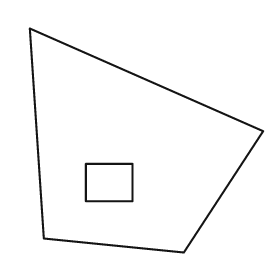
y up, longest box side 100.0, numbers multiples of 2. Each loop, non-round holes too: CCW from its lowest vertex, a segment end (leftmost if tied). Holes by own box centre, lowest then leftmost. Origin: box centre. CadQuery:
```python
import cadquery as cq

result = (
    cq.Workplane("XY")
    .moveTo(16.0, -48.0)
    .lineTo(50.0, 4.0)
    .lineTo(-50.0, 48.0)
    .lineTo(-44.0, -42.0)
    .close()
    .moveTo(-26.0, -26.0)
    .lineTo(-6.0, -26.0)
    .lineTo(-6.0, -10.0)
    .lineTo(-26.0, -10.0)
    .close()
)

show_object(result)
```